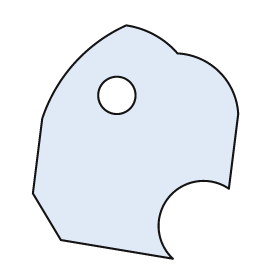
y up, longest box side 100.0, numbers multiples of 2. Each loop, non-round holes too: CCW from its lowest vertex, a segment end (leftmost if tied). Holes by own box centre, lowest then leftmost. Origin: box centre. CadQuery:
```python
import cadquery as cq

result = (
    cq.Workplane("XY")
    .moveTo(16.0, -50.0)
    .threePointArc((14.0, -24.0), (40.0, -20.0))
    .lineTo(44.0, 12.0)
    .threePointArc((36.0, 30.0), (18.0, 38.0))
    .threePointArc((8.0, 46.0), (-4.0, 50.0))
    .threePointArc((-26.0, 34.0), (-40.0, 10.0))
    .lineTo(-44.0, -22.0)
    .lineTo(-32.0, -42.0)
    .close()
    .moveTo(-8.0, 20.0)
    .circle(8.0)
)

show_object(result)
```